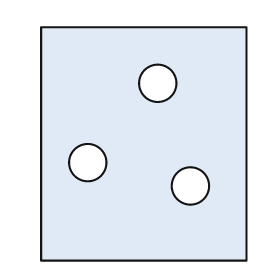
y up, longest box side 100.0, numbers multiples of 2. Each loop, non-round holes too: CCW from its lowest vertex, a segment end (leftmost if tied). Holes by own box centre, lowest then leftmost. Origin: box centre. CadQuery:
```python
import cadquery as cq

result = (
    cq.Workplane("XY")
    .moveTo(-44.0, -50.0)
    .lineTo(44.0, -50.0)
    .lineTo(44.0, 50.0)
    .lineTo(-44.0, 50.0)
    .close()
    .moveTo(20.0, -18.0)
    .circle(8.0)
    .moveTo(-24.0, -8.0)
    .circle(8.0)
    .moveTo(6.0, 26.0)
    .circle(8.0)
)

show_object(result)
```